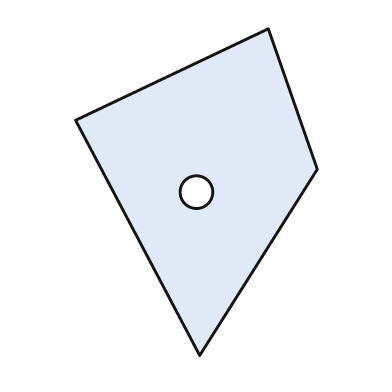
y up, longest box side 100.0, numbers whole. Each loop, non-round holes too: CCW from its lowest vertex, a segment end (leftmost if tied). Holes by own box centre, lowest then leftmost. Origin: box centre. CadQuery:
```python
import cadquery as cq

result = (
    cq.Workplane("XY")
    .moveTo(1.0, -50.0)
    .lineTo(37.0, 7.0)
    .lineTo(22.0, 50.0)
    .lineTo(-37.0, 22.0)
    .close()
    .moveTo(0.0, 0.0)
    .circle(5.0)
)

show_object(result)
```